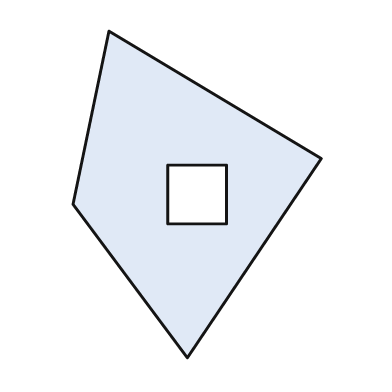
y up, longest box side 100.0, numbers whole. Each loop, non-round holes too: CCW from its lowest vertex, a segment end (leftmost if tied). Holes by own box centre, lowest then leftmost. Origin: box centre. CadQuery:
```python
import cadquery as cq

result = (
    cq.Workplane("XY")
    .moveTo(-3.0, -50.0)
    .lineTo(38.0, 11.0)
    .lineTo(-27.0, 50.0)
    .lineTo(-38.0, -3.0)
    .close()
    .moveTo(-9.0, -9.0)
    .lineTo(9.0, -9.0)
    .lineTo(9.0, 9.0)
    .lineTo(-9.0, 9.0)
    .close()
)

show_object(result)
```